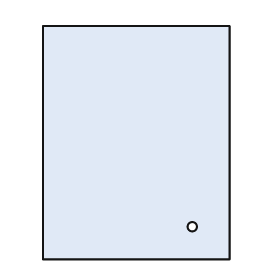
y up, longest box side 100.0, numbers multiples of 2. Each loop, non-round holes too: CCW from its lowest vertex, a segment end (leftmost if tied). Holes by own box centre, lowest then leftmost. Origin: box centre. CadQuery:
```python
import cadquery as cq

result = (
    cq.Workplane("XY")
    .moveTo(-40.0, -50.0)
    .lineTo(40.0, -50.0)
    .lineTo(40.0, 50.0)
    .lineTo(-40.0, 50.0)
    .close()
    .moveTo(24.0, -36.0)
    .circle(2.0)
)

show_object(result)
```